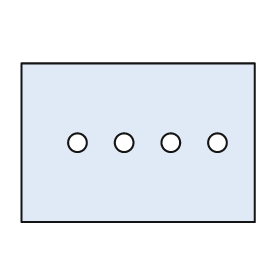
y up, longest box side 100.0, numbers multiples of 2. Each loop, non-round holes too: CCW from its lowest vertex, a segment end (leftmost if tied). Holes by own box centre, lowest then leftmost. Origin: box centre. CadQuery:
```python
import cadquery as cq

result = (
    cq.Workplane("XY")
    .moveTo(-50.0, -34.0)
    .lineTo(50.0, -34.0)
    .lineTo(50.0, 34.0)
    .lineTo(-50.0, 34.0)
    .close()
    .moveTo(-26.0, 0.0)
    .circle(4.0)
    .moveTo(-6.0, 0.0)
    .circle(4.0)
    .moveTo(14.0, 0.0)
    .circle(4.0)
    .moveTo(34.0, 0.0)
    .circle(4.0)
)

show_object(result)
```